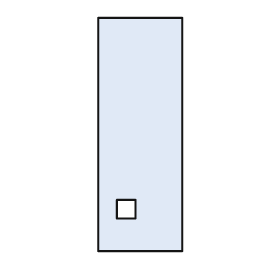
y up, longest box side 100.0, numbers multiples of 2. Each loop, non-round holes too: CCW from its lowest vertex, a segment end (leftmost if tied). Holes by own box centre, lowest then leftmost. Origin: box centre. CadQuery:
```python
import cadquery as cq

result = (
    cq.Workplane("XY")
    .moveTo(-18.0, -50.0)
    .lineTo(18.0, -50.0)
    .lineTo(18.0, 50.0)
    .lineTo(-18.0, 50.0)
    .close()
    .moveTo(-10.0, -36.0)
    .lineTo(-2.0, -36.0)
    .lineTo(-2.0, -28.0)
    .lineTo(-10.0, -28.0)
    .close()
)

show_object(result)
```